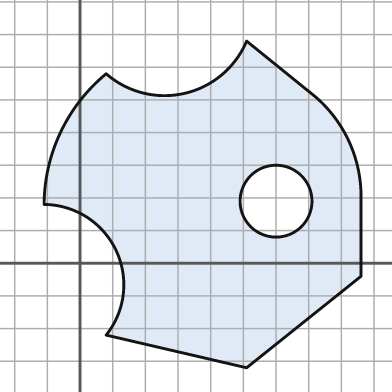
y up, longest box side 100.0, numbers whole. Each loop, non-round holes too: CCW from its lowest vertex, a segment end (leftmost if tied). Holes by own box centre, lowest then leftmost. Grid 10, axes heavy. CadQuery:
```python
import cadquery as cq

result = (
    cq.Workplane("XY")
    .moveTo(51.0, -32.0)
    .lineTo(86.0, -4.0)
    .lineTo(86.0, 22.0)
    .threePointArc((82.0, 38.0), (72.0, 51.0))
    .lineTo(51.0, 68.0)
    .threePointArc((32.0, 52.0), (8.0, 58.0))
    .threePointArc((-6.0, 40.0), (-11.0, 18.0))
    .threePointArc((11.0, 4.0), (8.0, -22.0))
    .close()
    .moveTo(60.0, 19.0)
    .circle(11.0)
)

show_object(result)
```